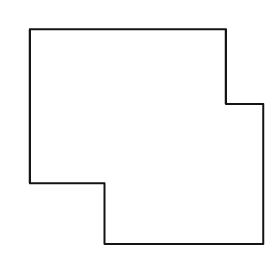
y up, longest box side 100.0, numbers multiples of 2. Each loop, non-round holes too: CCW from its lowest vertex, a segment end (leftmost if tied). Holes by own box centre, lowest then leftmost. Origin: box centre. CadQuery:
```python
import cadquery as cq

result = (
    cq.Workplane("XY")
    .moveTo(-18.0, -46.0)
    .lineTo(50.0, -46.0)
    .lineTo(50.0, 14.0)
    .lineTo(34.0, 14.0)
    .lineTo(34.0, 46.0)
    .lineTo(-50.0, 46.0)
    .lineTo(-50.0, -20.0)
    .lineTo(-18.0, -20.0)
    .close()
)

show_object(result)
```